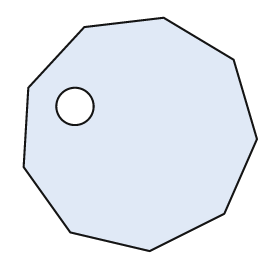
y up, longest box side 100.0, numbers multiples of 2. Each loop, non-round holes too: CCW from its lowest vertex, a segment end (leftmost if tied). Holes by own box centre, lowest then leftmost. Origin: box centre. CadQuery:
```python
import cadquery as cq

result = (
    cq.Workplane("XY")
    .moveTo(4.0, -50.0)
    .lineTo(36.0, -34.0)
    .lineTo(50.0, -2.0)
    .lineTo(40.0, 32.0)
    .lineTo(10.0, 50.0)
    .lineTo(-24.0, 46.0)
    .lineTo(-48.0, 20.0)
    .lineTo(-50.0, -14.0)
    .lineTo(-30.0, -42.0)
    .close()
    .moveTo(-28.0, 12.0)
    .circle(8.0)
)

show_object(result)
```